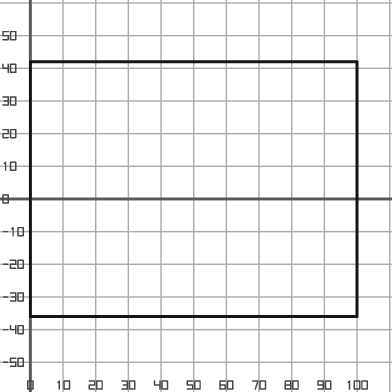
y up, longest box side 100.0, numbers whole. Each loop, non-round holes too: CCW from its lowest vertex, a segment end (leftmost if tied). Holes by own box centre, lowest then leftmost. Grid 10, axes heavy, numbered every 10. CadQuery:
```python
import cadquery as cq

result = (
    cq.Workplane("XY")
    .moveTo(0.0, -36.0)
    .lineTo(100.0, -36.0)
    .lineTo(100.0, 42.0)
    .lineTo(0.0, 42.0)
    .close()
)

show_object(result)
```